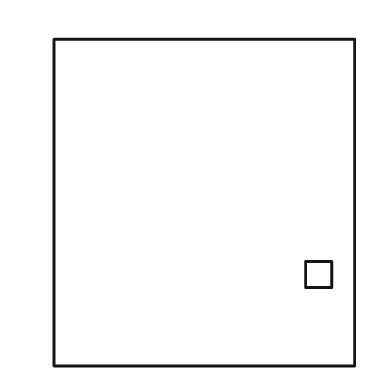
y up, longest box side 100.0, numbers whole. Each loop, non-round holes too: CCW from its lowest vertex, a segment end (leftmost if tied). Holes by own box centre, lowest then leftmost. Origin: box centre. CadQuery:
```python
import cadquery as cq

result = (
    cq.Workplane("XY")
    .moveTo(-46.0, -50.0)
    .lineTo(46.0, -50.0)
    .lineTo(46.0, 50.0)
    .lineTo(-46.0, 50.0)
    .close()
    .moveTo(31.0, -26.0)
    .lineTo(39.0, -26.0)
    .lineTo(39.0, -18.0)
    .lineTo(31.0, -18.0)
    .close()
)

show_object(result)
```